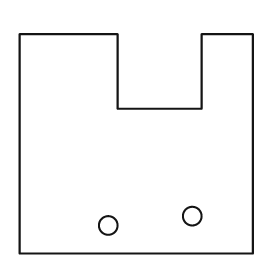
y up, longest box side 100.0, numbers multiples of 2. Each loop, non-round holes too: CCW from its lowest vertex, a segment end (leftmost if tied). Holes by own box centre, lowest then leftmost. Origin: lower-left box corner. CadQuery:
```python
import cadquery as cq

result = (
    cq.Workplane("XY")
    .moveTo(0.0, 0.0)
    .lineTo(100.0, 0.0)
    .lineTo(100.0, 94.0)
    .lineTo(78.0, 94.0)
    .lineTo(78.0, 62.0)
    .lineTo(42.0, 62.0)
    .lineTo(42.0, 94.0)
    .lineTo(0.0, 94.0)
    .close()
    .moveTo(38.0, 12.0)
    .circle(4.0)
    .moveTo(74.0, 16.0)
    .circle(4.0)
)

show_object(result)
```